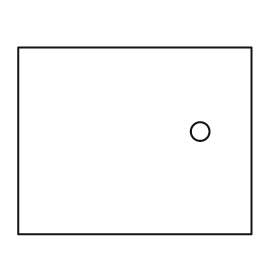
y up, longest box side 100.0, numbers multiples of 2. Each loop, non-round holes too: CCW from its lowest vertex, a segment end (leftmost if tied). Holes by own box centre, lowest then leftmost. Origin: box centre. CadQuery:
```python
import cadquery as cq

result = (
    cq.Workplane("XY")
    .moveTo(-50.0, -40.0)
    .lineTo(50.0, -40.0)
    .lineTo(50.0, 40.0)
    .lineTo(-50.0, 40.0)
    .close()
    .moveTo(28.0, 4.0)
    .circle(4.0)
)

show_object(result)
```